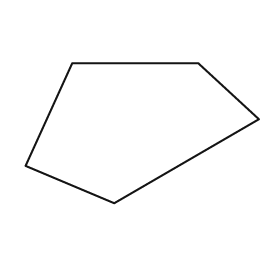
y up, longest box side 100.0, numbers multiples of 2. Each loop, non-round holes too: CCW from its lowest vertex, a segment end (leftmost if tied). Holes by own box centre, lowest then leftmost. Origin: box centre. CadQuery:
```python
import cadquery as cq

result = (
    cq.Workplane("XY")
    .moveTo(-12.0, -30.0)
    .lineTo(50.0, 6.0)
    .lineTo(24.0, 30.0)
    .lineTo(-30.0, 30.0)
    .lineTo(-50.0, -14.0)
    .close()
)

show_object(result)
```